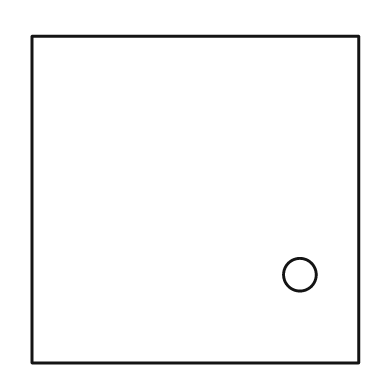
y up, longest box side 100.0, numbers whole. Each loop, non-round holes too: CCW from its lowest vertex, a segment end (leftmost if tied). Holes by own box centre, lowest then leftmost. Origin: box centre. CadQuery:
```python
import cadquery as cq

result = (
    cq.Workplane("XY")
    .moveTo(-50.0, -50.0)
    .lineTo(50.0, -50.0)
    .lineTo(50.0, 50.0)
    .lineTo(-50.0, 50.0)
    .close()
    .moveTo(32.0, -23.0)
    .circle(5.0)
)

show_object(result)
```